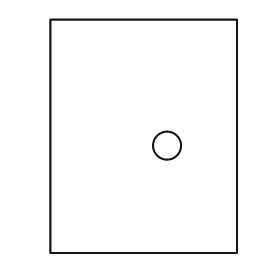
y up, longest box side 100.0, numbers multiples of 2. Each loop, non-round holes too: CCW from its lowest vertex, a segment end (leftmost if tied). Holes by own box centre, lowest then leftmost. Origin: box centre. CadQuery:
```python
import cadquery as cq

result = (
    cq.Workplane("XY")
    .moveTo(-40.0, -50.0)
    .lineTo(40.0, -50.0)
    .lineTo(40.0, 50.0)
    .lineTo(-40.0, 50.0)
    .close()
    .moveTo(10.0, -4.0)
    .circle(6.0)
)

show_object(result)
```